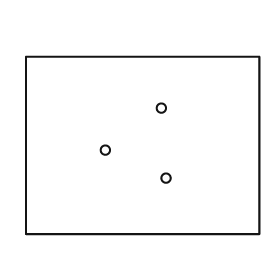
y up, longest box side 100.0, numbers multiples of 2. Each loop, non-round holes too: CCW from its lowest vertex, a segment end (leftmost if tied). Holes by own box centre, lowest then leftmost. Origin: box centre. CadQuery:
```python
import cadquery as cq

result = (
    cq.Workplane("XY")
    .moveTo(-50.0, -38.0)
    .lineTo(50.0, -38.0)
    .lineTo(50.0, 38.0)
    .lineTo(-50.0, 38.0)
    .close()
    .moveTo(10.0, -14.0)
    .circle(2.0)
    .moveTo(-16.0, -2.0)
    .circle(2.0)
    .moveTo(8.0, 16.0)
    .circle(2.0)
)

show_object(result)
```